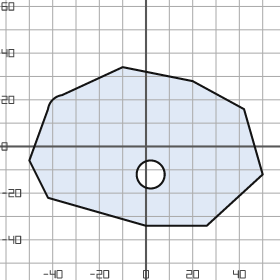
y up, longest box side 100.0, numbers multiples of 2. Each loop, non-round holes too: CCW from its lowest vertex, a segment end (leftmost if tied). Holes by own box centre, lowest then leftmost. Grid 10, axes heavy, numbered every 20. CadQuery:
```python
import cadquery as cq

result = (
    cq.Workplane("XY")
    .moveTo(0.0, -34.0)
    .lineTo(26.0, -34.0)
    .lineTo(50.0, -12.0)
    .lineTo(42.0, 16.0)
    .lineTo(20.0, 28.0)
    .lineTo(-10.0, 34.0)
    .lineTo(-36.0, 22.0)
    .threePointArc((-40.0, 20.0), (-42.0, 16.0))
    .lineTo(-50.0, -6.0)
    .lineTo(-42.0, -22.0)
    .close()
    .moveTo(2.0, -12.0)
    .circle(6.0)
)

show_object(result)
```